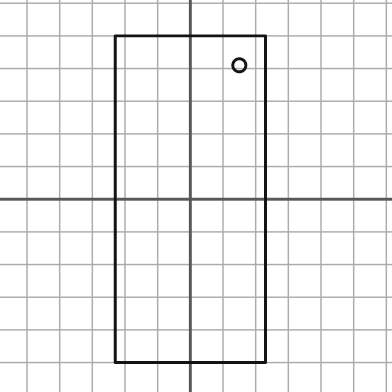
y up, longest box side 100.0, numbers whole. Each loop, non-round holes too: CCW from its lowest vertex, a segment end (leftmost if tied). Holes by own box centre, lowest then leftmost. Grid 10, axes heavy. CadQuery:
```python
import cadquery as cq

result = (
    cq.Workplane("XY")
    .moveTo(-23.0, -50.0)
    .lineTo(23.0, -50.0)
    .lineTo(23.0, 50.0)
    .lineTo(-23.0, 50.0)
    .close()
    .moveTo(15.0, 41.0)
    .circle(2.0)
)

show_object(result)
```